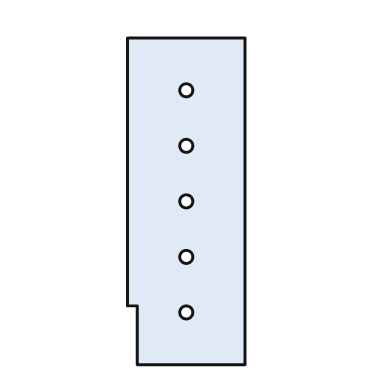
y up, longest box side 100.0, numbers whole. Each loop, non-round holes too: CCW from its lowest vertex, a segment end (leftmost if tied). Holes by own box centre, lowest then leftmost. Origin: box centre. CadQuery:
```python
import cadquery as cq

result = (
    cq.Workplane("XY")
    .moveTo(-15.0, -50.0)
    .lineTo(18.0, -50.0)
    .lineTo(18.0, 50.0)
    .lineTo(-18.0, 50.0)
    .lineTo(-18.0, -32.0)
    .lineTo(-15.0, -32.0)
    .close()
    .moveTo(0.0, -34.0)
    .circle(2.0)
    .moveTo(0.0, -17.0)
    .circle(2.0)
    .moveTo(0.0, 0.0)
    .circle(2.0)
    .moveTo(0.0, 17.0)
    .circle(2.0)
    .moveTo(0.0, 34.0)
    .circle(2.0)
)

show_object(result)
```